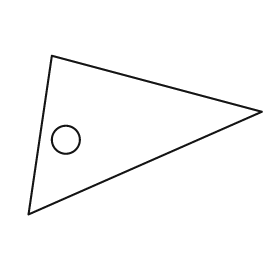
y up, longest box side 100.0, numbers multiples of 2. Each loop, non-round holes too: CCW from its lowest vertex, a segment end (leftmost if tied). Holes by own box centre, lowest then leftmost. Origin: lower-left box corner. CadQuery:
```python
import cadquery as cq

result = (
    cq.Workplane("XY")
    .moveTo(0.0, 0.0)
    .lineTo(100.0, 44.0)
    .lineTo(10.0, 68.0)
    .close()
    .moveTo(16.0, 32.0)
    .circle(6.0)
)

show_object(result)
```